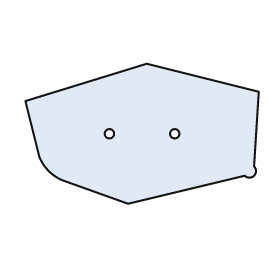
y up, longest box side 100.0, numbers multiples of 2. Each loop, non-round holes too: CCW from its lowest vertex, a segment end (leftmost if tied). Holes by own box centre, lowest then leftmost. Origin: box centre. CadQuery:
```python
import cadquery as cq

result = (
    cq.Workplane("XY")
    .moveTo(-6.0, -30.0)
    .lineTo(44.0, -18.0)
    .threePointArc((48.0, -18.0), (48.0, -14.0))
    .lineTo(50.0, 18.0)
    .lineTo(2.0, 30.0)
    .lineTo(-50.0, 14.0)
    .lineTo(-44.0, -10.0)
    .threePointArc((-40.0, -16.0), (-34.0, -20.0))
    .close()
    .moveTo(-14.0, 0.0)
    .circle(2.0)
    .moveTo(14.0, 0.0)
    .circle(2.0)
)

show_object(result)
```